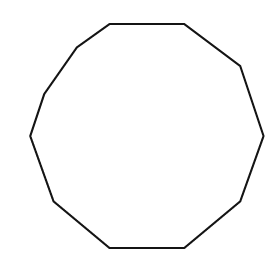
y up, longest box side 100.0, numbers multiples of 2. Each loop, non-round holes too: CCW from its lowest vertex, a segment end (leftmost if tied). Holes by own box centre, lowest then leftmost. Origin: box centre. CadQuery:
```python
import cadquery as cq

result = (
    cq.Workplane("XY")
    .moveTo(-16.0, -48.0)
    .lineTo(16.0, -48.0)
    .lineTo(40.0, -28.0)
    .lineTo(50.0, 0.0)
    .lineTo(40.0, 30.0)
    .lineTo(16.0, 48.0)
    .lineTo(-16.0, 48.0)
    .lineTo(-30.0, 38.0)
    .lineTo(-44.0, 18.0)
    .lineTo(-50.0, 0.0)
    .lineTo(-40.0, -28.0)
    .close()
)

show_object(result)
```